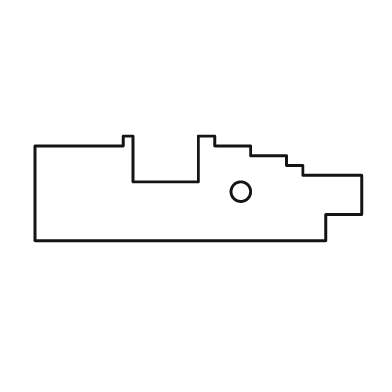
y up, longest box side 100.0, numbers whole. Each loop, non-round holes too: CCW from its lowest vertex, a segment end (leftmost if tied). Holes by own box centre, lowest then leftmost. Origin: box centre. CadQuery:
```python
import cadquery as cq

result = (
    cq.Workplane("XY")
    .moveTo(-50.0, -16.0)
    .lineTo(39.0, -16.0)
    .lineTo(39.0, -8.0)
    .lineTo(50.0, -8.0)
    .lineTo(50.0, 4.0)
    .lineTo(32.0, 4.0)
    .lineTo(32.0, 7.0)
    .lineTo(27.0, 7.0)
    .lineTo(27.0, 10.0)
    .lineTo(16.0, 10.0)
    .lineTo(16.0, 13.0)
    .lineTo(5.0, 13.0)
    .lineTo(5.0, 16.0)
    .lineTo(0.0, 16.0)
    .lineTo(0.0, 2.0)
    .lineTo(-20.0, 2.0)
    .lineTo(-20.0, 16.0)
    .lineTo(-23.0, 16.0)
    .lineTo(-23.0, 13.0)
    .lineTo(-50.0, 13.0)
    .close()
    .moveTo(13.0, -1.0)
    .circle(3.0)
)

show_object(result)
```